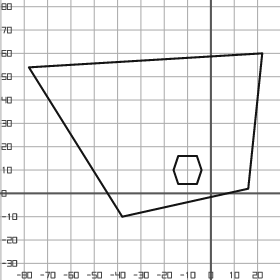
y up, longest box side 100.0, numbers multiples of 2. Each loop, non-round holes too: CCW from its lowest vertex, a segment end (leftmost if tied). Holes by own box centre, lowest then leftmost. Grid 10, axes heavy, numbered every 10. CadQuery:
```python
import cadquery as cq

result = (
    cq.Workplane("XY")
    .moveTo(-38.0, -10.0)
    .lineTo(16.0, 2.0)
    .lineTo(22.0, 60.0)
    .lineTo(-78.0, 54.0)
    .close()
    .moveTo(-14.0, 4.0)
    .lineTo(-6.0, 4.0)
    .lineTo(-4.0, 10.0)
    .lineTo(-6.0, 16.0)
    .lineTo(-14.0, 16.0)
    .lineTo(-16.0, 10.0)
    .close()
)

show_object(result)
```